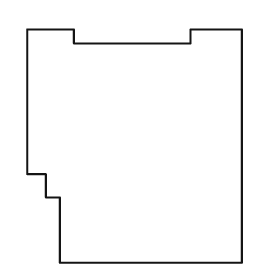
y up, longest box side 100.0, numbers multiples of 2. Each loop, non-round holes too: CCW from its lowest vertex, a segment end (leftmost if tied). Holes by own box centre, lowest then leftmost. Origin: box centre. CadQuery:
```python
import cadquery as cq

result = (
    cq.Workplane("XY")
    .moveTo(-32.0, -50.0)
    .lineTo(46.0, -50.0)
    .lineTo(46.0, 50.0)
    .lineTo(24.0, 50.0)
    .lineTo(24.0, 44.0)
    .lineTo(-26.0, 44.0)
    .lineTo(-26.0, 50.0)
    .lineTo(-46.0, 50.0)
    .lineTo(-46.0, -12.0)
    .lineTo(-38.0, -12.0)
    .lineTo(-38.0, -22.0)
    .lineTo(-32.0, -22.0)
    .close()
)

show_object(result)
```